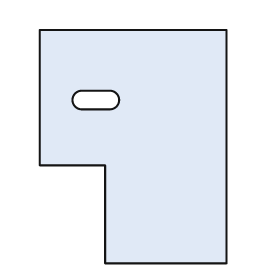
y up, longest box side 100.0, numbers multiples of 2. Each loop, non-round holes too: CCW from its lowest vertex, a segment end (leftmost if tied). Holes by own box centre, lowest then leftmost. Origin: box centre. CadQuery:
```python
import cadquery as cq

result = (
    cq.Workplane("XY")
    .moveTo(-12.0, -50.0)
    .lineTo(40.0, -50.0)
    .lineTo(40.0, 50.0)
    .lineTo(-40.0, 50.0)
    .lineTo(-40.0, -8.0)
    .lineTo(-12.0, -8.0)
    .close()
    .moveTo(-22.0, 16.0)
    .lineTo(-10.0, 16.0)
    .threePointArc((-6.0, 20.0), (-10.0, 24.0))
    .lineTo(-22.0, 24.0)
    .threePointArc((-26.0, 20.0), (-22.0, 16.0))
    .close()
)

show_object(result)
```